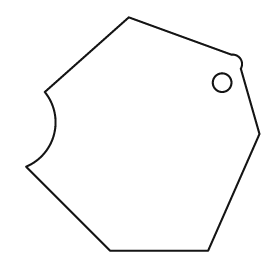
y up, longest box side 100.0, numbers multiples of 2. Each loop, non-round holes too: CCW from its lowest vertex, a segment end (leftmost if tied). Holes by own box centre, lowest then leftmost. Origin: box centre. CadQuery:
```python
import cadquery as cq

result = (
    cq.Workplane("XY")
    .moveTo(-14.0, -50.0)
    .lineTo(28.0, -50.0)
    .lineTo(50.0, 0.0)
    .lineTo(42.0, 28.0)
    .threePointArc((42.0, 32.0), (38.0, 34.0))
    .lineTo(-6.0, 50.0)
    .lineTo(-42.0, 18.0)
    .threePointArc((-38.0, 0.0), (-50.0, -14.0))
    .close()
    .moveTo(34.0, 22.0)
    .circle(4.0)
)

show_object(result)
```